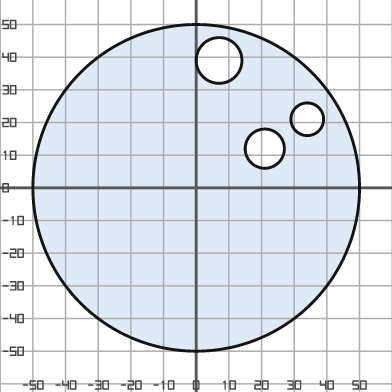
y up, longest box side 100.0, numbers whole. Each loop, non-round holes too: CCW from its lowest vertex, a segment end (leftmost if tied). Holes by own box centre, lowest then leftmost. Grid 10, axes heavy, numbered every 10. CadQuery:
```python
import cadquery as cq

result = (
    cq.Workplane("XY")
    .moveTo(0.0, 0.0)
    .circle(50.0)
    .moveTo(21.0, 12.0)
    .circle(6.0)
    .moveTo(34.0, 21.0)
    .circle(5.0)
    .moveTo(7.0, 39.0)
    .circle(7.0)
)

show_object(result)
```